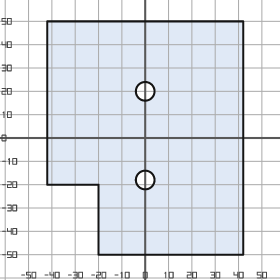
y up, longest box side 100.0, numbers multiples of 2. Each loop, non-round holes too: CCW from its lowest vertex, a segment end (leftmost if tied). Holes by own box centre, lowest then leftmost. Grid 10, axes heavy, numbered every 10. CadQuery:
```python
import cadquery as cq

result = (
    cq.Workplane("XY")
    .moveTo(-20.0, -50.0)
    .lineTo(42.0, -50.0)
    .lineTo(42.0, 50.0)
    .lineTo(-42.0, 50.0)
    .lineTo(-42.0, -20.0)
    .lineTo(-20.0, -20.0)
    .close()
    .moveTo(0.0, -18.0)
    .circle(4.0)
    .moveTo(0.0, 20.0)
    .circle(4.0)
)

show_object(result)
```